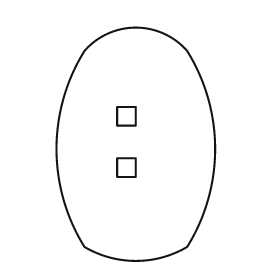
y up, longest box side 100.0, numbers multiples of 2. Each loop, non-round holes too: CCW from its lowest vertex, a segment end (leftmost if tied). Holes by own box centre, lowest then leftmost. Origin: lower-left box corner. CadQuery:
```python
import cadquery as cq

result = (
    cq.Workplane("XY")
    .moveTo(12.0, 6.0)
    .threePointArc((34.0, 0.0), (56.0, 6.0))
    .threePointArc((68.0, 48.0), (56.0, 90.0))
    .threePointArc((34.0, 100.0), (12.0, 90.0))
    .threePointArc((0.0, 48.0), (12.0, 6.0))
    .close()
    .moveTo(26.0, 36.0)
    .lineTo(34.0, 36.0)
    .lineTo(34.0, 44.0)
    .lineTo(26.0, 44.0)
    .close()
    .moveTo(26.0, 58.0)
    .lineTo(34.0, 58.0)
    .lineTo(34.0, 66.0)
    .lineTo(26.0, 66.0)
    .close()
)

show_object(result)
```